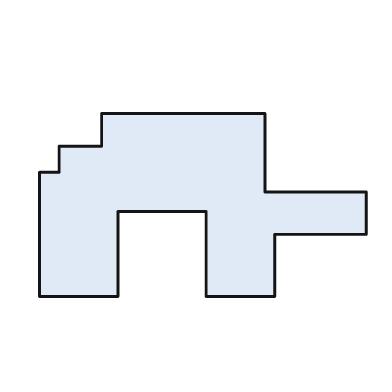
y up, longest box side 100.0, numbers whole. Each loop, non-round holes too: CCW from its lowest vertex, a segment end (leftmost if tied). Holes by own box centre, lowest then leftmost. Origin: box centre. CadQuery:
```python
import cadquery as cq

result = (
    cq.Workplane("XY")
    .moveTo(-50.0, -28.0)
    .lineTo(-26.0, -28.0)
    .lineTo(-26.0, -2.0)
    .lineTo(1.0, -2.0)
    .lineTo(1.0, -28.0)
    .lineTo(22.0, -28.0)
    .lineTo(22.0, -9.0)
    .lineTo(50.0, -9.0)
    .lineTo(50.0, 4.0)
    .lineTo(19.0, 4.0)
    .lineTo(19.0, 28.0)
    .lineTo(-31.0, 28.0)
    .lineTo(-31.0, 18.0)
    .lineTo(-44.0, 18.0)
    .lineTo(-44.0, 10.0)
    .lineTo(-50.0, 10.0)
    .close()
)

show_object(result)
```